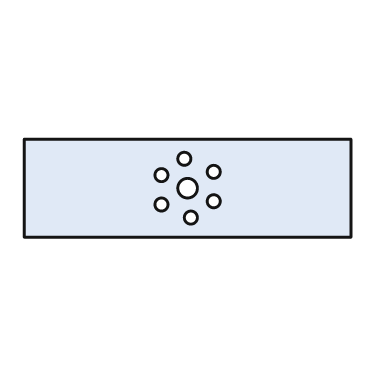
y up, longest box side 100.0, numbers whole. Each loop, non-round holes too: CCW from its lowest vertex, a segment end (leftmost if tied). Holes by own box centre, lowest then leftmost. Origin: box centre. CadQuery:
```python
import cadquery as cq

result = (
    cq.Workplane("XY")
    .moveTo(-50.0, -15.0)
    .lineTo(50.0, -15.0)
    .lineTo(50.0, 15.0)
    .lineTo(-50.0, 15.0)
    .close()
    .moveTo(1.0, -9.0)
    .circle(2.0)
    .moveTo(-8.0, -5.0)
    .circle(2.0)
    .moveTo(8.0, -4.0)
    .circle(2.0)
    .moveTo(0.0, 0.0)
    .circle(3.0)
    .moveTo(-8.0, 4.0)
    .circle(2.0)
    .moveTo(8.0, 5.0)
    .circle(2.0)
    .moveTo(-1.0, 9.0)
    .circle(2.0)
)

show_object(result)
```